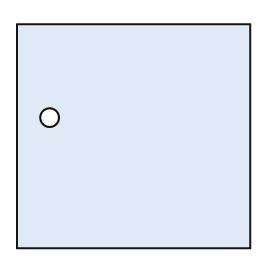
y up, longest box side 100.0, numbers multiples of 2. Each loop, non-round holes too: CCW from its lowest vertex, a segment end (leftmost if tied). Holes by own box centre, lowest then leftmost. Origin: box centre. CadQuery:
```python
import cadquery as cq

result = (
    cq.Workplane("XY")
    .moveTo(-50.0, -48.0)
    .lineTo(50.0, -48.0)
    .lineTo(50.0, 48.0)
    .lineTo(-50.0, 48.0)
    .close()
    .moveTo(-36.0, 8.0)
    .circle(4.0)
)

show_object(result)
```